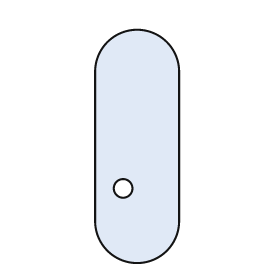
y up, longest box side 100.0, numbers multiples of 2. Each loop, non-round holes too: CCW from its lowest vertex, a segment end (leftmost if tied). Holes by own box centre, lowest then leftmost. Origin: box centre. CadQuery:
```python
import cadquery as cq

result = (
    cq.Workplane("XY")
    .moveTo(-18.0, -32.0)
    .threePointArc((0.0, -50.0), (18.0, -32.0))
    .lineTo(18.0, 32.0)
    .threePointArc((0.0, 50.0), (-18.0, 32.0))
    .close()
    .moveTo(-6.0, -18.0)
    .circle(4.0)
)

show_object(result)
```